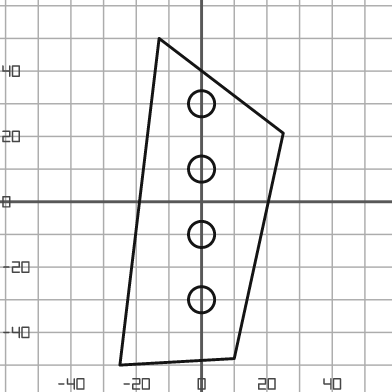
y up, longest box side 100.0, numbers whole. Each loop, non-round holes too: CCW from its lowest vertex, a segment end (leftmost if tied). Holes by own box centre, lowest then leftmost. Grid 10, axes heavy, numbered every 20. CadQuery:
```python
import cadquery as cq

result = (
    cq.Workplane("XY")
    .moveTo(-25.0, -50.0)
    .lineTo(10.0, -48.0)
    .lineTo(25.0, 21.0)
    .lineTo(-13.0, 50.0)
    .close()
    .moveTo(0.0, -30.0)
    .circle(4.0)
    .moveTo(0.0, -10.0)
    .circle(4.0)
    .moveTo(0.0, 10.0)
    .circle(4.0)
    .moveTo(0.0, 30.0)
    .circle(4.0)
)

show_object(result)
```